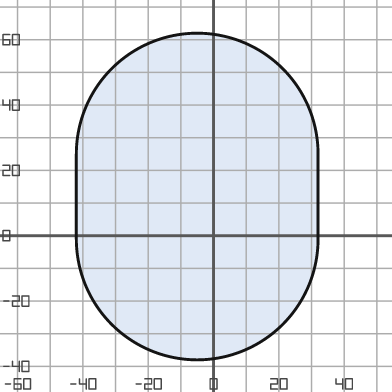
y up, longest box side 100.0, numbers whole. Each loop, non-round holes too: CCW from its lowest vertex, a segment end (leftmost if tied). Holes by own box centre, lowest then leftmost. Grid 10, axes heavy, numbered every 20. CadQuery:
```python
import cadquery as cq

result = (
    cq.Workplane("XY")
    .moveTo(-42.0, -1.0)
    .threePointArc((-5.0, -38.0), (32.0, -1.0))
    .lineTo(32.0, 25.0)
    .threePointArc((-5.0, 62.0), (-42.0, 25.0))
    .close()
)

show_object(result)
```